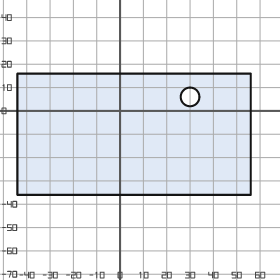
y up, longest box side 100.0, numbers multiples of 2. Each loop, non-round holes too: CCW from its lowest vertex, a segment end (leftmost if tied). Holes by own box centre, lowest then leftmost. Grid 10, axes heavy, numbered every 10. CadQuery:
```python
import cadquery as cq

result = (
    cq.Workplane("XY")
    .moveTo(-44.0, -36.0)
    .lineTo(56.0, -36.0)
    .lineTo(56.0, 16.0)
    .lineTo(-44.0, 16.0)
    .close()
    .moveTo(30.0, 6.0)
    .circle(4.0)
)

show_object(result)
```